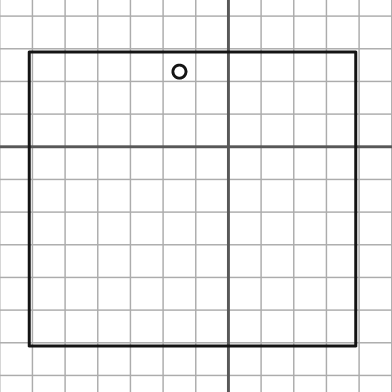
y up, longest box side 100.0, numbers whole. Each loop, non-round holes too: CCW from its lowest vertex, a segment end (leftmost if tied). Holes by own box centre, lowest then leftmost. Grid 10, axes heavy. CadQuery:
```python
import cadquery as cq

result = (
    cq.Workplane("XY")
    .moveTo(-61.0, -61.0)
    .lineTo(39.0, -61.0)
    .lineTo(39.0, 29.0)
    .lineTo(-61.0, 29.0)
    .close()
    .moveTo(-15.0, 23.0)
    .circle(2.0)
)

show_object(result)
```